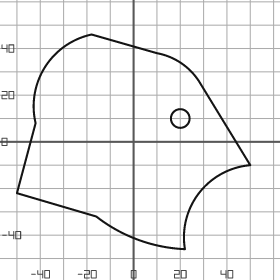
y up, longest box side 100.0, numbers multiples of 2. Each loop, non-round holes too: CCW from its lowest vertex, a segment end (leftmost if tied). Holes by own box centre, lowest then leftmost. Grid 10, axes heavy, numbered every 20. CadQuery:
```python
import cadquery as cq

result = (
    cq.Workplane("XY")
    .moveTo(22.0, -46.0)
    .threePointArc((28.0, -22.0), (50.0, -10.0))
    .lineTo(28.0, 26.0)
    .threePointArc((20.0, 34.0), (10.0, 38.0))
    .lineTo(-18.0, 46.0)
    .threePointArc((-38.0, 32.0), (-42.0, 8.0))
    .lineTo(-50.0, -22.0)
    .lineTo(-16.0, -32.0)
    .threePointArc((2.0, -42.0), (22.0, -46.0))
    .close()
    .moveTo(20.0, 10.0)
    .circle(4.0)
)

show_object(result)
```